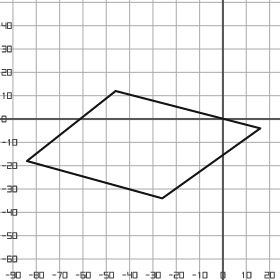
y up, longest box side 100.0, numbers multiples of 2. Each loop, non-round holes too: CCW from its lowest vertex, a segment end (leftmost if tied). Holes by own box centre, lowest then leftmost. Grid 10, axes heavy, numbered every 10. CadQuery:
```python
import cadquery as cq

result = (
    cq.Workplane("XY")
    .moveTo(-26.0, -34.0)
    .lineTo(16.0, -4.0)
    .lineTo(-46.0, 12.0)
    .lineTo(-84.0, -18.0)
    .close()
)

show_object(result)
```